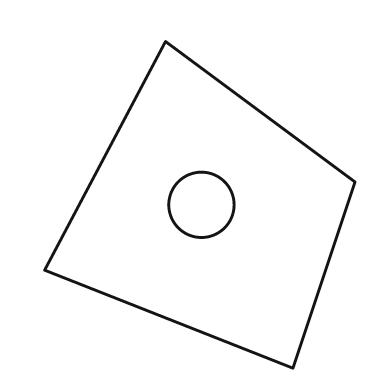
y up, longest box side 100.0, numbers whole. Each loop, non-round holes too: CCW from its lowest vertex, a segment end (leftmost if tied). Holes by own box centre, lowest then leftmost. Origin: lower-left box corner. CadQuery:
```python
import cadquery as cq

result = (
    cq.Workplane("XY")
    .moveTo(76.0, 0.0)
    .lineTo(95.0, 57.0)
    .lineTo(37.0, 100.0)
    .lineTo(0.0, 30.0)
    .close()
    .moveTo(48.0, 50.0)
    .circle(10.0)
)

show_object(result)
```